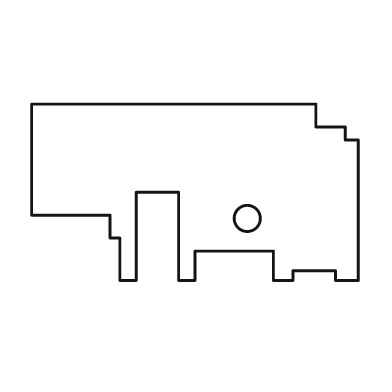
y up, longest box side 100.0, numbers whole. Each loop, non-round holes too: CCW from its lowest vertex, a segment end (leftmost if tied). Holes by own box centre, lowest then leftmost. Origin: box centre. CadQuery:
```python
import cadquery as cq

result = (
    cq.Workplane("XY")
    .moveTo(-23.0, -27.0)
    .lineTo(-18.0, -27.0)
    .lineTo(-18.0, 0.0)
    .lineTo(-5.0, 0.0)
    .lineTo(-5.0, -27.0)
    .lineTo(0.0, -27.0)
    .lineTo(0.0, -18.0)
    .lineTo(24.0, -18.0)
    .lineTo(24.0, -27.0)
    .lineTo(30.0, -27.0)
    .lineTo(30.0, -24.0)
    .lineTo(43.0, -24.0)
    .lineTo(43.0, -27.0)
    .lineTo(50.0, -27.0)
    .lineTo(50.0, 16.0)
    .lineTo(46.0, 16.0)
    .lineTo(46.0, 20.0)
    .lineTo(37.0, 20.0)
    .lineTo(37.0, 27.0)
    .lineTo(-50.0, 27.0)
    .lineTo(-50.0, -7.0)
    .lineTo(-26.0, -7.0)
    .lineTo(-26.0, -14.0)
    .lineTo(-23.0, -14.0)
    .close()
    .moveTo(16.0, -8.0)
    .circle(4.0)
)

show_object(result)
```